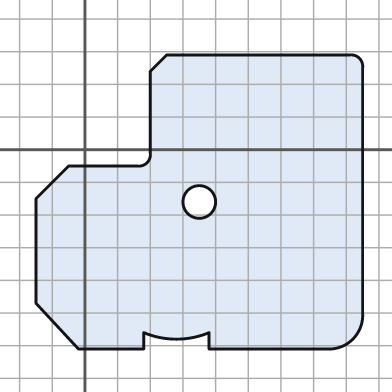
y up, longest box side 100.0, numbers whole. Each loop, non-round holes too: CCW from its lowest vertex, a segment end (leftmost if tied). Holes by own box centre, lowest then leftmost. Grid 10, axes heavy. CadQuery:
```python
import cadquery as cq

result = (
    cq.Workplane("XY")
    .moveTo(-2.0, -61.0)
    .lineTo(18.0, -61.0)
    .lineTo(18.0, -56.0)
    .threePointArc((28.0, -58.0), (38.0, -56.0))
    .lineTo(38.0, -61.0)
    .lineTo(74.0, -61.0)
    .threePointArc((82.0, -58.0), (85.0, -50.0))
    .lineTo(85.0, 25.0)
    .threePointArc((84.0, 28.0), (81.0, 29.0))
    .lineTo(25.0, 29.0)
    .lineTo(20.0, 24.0)
    .lineTo(20.0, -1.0)
    .threePointArc((19.0, -4.0), (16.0, -5.0))
    .lineTo(-5.0, -5.0)
    .lineTo(-15.0, -15.0)
    .lineTo(-15.0, -47.0)
    .close()
    .moveTo(35.0, -16.0)
    .circle(5.0)
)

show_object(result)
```